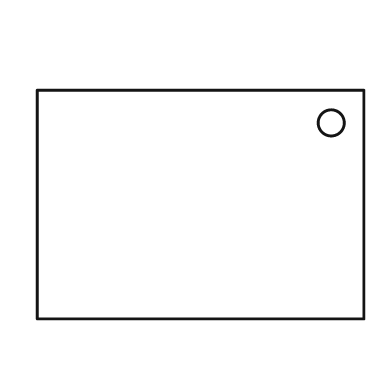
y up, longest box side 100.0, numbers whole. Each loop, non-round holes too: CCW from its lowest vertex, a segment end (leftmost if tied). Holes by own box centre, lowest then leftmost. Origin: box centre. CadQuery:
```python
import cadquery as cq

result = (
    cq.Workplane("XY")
    .moveTo(-50.0, -35.0)
    .lineTo(50.0, -35.0)
    .lineTo(50.0, 35.0)
    .lineTo(-50.0, 35.0)
    .close()
    .moveTo(40.0, 25.0)
    .circle(4.0)
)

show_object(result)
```